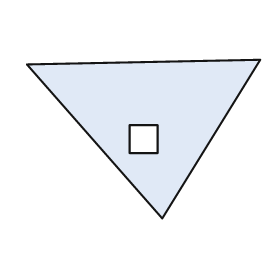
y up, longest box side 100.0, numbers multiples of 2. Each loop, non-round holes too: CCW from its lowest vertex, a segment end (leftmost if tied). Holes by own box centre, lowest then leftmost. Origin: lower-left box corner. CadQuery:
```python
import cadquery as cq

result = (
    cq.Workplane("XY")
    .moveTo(58.0, 0.0)
    .lineTo(100.0, 68.0)
    .lineTo(0.0, 66.0)
    .close()
    .moveTo(44.0, 28.0)
    .lineTo(56.0, 28.0)
    .lineTo(56.0, 40.0)
    .lineTo(44.0, 40.0)
    .close()
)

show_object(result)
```